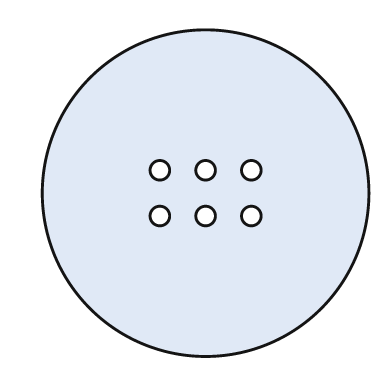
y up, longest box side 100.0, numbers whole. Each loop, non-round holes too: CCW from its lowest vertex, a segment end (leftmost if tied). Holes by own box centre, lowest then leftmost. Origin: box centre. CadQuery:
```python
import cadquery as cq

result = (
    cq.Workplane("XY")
    .moveTo(0.0, 0.0)
    .circle(50.0)
    .moveTo(-14.0, -7.0)
    .circle(3.0)
    .moveTo(0.0, -7.0)
    .circle(3.0)
    .moveTo(14.0, -7.0)
    .circle(3.0)
    .moveTo(-14.0, 7.0)
    .circle(3.0)
    .moveTo(0.0, 7.0)
    .circle(3.0)
    .moveTo(14.0, 7.0)
    .circle(3.0)
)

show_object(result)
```